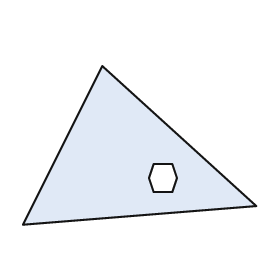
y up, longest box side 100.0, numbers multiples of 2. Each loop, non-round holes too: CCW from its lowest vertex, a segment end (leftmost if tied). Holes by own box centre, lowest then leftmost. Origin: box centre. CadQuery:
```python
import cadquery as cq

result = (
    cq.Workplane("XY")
    .moveTo(-50.0, -34.0)
    .lineTo(50.0, -26.0)
    .lineTo(-16.0, 34.0)
    .close()
    .moveTo(6.0, -20.0)
    .lineTo(14.0, -20.0)
    .lineTo(16.0, -14.0)
    .lineTo(14.0, -8.0)
    .lineTo(6.0, -8.0)
    .lineTo(4.0, -14.0)
    .close()
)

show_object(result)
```